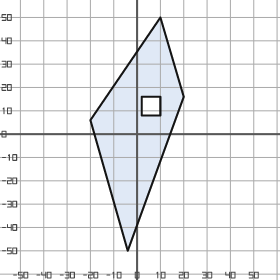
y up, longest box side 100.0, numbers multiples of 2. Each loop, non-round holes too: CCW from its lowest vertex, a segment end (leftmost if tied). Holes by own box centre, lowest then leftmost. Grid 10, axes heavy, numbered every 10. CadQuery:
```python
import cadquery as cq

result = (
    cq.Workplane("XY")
    .moveTo(-4.0, -50.0)
    .lineTo(20.0, 16.0)
    .lineTo(10.0, 50.0)
    .lineTo(-20.0, 6.0)
    .close()
    .moveTo(2.0, 8.0)
    .lineTo(10.0, 8.0)
    .lineTo(10.0, 16.0)
    .lineTo(2.0, 16.0)
    .close()
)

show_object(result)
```